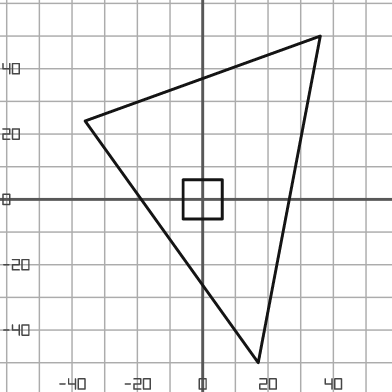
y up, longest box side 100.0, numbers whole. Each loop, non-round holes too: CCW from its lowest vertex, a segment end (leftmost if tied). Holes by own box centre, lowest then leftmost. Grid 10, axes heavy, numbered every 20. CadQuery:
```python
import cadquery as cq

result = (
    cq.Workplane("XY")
    .moveTo(17.0, -50.0)
    .lineTo(36.0, 50.0)
    .lineTo(-36.0, 24.0)
    .close()
    .moveTo(-6.0, -6.0)
    .lineTo(6.0, -6.0)
    .lineTo(6.0, 6.0)
    .lineTo(-6.0, 6.0)
    .close()
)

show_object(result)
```